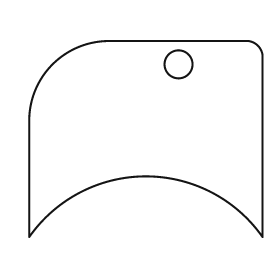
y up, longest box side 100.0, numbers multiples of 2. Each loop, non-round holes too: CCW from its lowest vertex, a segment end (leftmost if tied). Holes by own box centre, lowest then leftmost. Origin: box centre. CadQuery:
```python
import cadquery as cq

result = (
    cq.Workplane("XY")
    .moveTo(-50.0, -42.0)
    .threePointArc((0.0, -16.0), (50.0, -42.0))
    .lineTo(50.0, 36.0)
    .threePointArc((48.0, 40.0), (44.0, 42.0))
    .lineTo(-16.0, 42.0)
    .threePointArc((-40.0, 32.0), (-50.0, 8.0))
    .close()
    .moveTo(14.0, 32.0)
    .circle(6.0)
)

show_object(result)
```